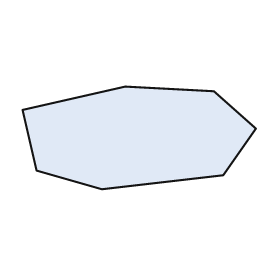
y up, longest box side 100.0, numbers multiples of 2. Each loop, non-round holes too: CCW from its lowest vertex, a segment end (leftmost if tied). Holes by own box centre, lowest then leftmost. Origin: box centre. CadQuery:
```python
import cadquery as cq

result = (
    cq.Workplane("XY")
    .moveTo(-16.0, -22.0)
    .lineTo(36.0, -16.0)
    .lineTo(50.0, 4.0)
    .lineTo(32.0, 20.0)
    .lineTo(-6.0, 22.0)
    .lineTo(-50.0, 12.0)
    .lineTo(-44.0, -14.0)
    .close()
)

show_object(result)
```